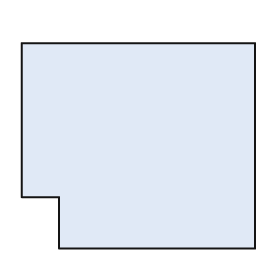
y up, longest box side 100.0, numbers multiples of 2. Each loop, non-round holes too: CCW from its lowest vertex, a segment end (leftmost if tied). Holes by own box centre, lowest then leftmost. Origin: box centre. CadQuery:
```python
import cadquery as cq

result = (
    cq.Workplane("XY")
    .moveTo(-34.0, -44.0)
    .lineTo(50.0, -44.0)
    .lineTo(50.0, 44.0)
    .lineTo(-50.0, 44.0)
    .lineTo(-50.0, -22.0)
    .lineTo(-34.0, -22.0)
    .close()
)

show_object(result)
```